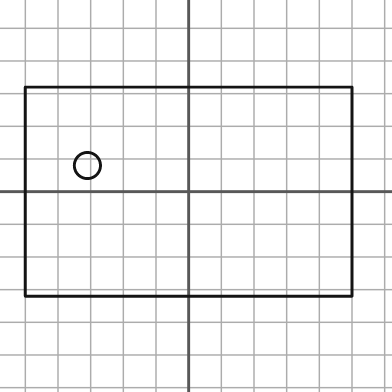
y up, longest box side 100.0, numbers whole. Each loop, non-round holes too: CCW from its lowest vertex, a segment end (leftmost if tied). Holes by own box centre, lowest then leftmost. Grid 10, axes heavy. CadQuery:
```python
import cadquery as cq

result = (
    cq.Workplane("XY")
    .moveTo(-50.0, -32.0)
    .lineTo(50.0, -32.0)
    .lineTo(50.0, 32.0)
    .lineTo(-50.0, 32.0)
    .close()
    .moveTo(-31.0, 8.0)
    .circle(4.0)
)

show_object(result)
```